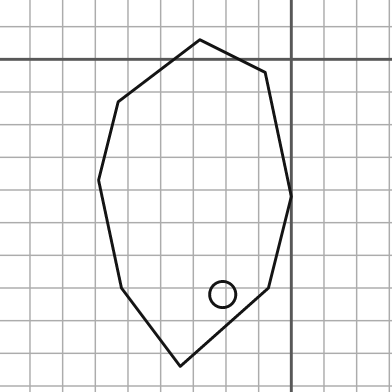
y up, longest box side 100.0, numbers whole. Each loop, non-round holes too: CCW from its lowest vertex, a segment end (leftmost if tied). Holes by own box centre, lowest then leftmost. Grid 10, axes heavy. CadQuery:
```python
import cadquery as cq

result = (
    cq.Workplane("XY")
    .moveTo(-34.0, -94.0)
    .lineTo(-7.0, -70.0)
    .lineTo(0.0, -42.0)
    .lineTo(-8.0, -4.0)
    .lineTo(-28.0, 6.0)
    .lineTo(-53.0, -13.0)
    .lineTo(-59.0, -37.0)
    .lineTo(-52.0, -70.0)
    .close()
    .moveTo(-21.0, -72.0)
    .circle(4.0)
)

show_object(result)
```